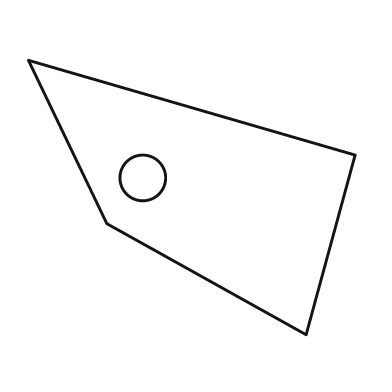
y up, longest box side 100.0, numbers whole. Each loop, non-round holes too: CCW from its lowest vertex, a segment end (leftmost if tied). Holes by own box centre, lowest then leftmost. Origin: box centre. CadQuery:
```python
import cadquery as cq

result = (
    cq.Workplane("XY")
    .moveTo(35.0, -42.0)
    .lineTo(50.0, 13.0)
    .lineTo(-50.0, 42.0)
    .lineTo(-26.0, -8.0)
    .close()
    .moveTo(-15.0, 6.0)
    .circle(7.0)
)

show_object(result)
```